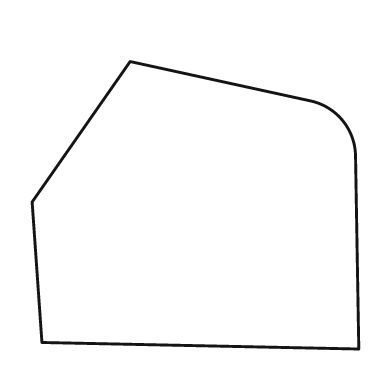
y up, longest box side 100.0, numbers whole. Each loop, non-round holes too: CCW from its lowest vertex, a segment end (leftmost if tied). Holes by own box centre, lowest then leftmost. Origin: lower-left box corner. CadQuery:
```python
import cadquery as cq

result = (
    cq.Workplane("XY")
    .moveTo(100.0, 0.0)
    .lineTo(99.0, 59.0)
    .threePointArc((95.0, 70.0), (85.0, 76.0))
    .lineTo(30.0, 88.0)
    .lineTo(0.0, 45.0)
    .lineTo(3.0, 2.0)
    .close()
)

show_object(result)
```